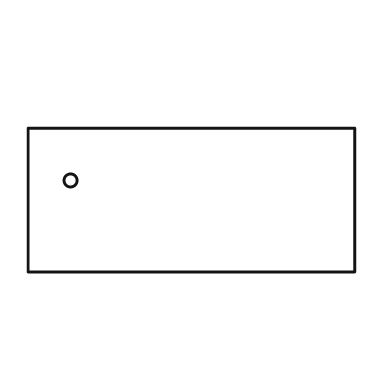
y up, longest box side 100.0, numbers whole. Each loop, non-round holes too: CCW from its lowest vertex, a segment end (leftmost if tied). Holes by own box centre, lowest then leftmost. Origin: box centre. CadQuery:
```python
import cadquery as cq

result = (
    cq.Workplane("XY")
    .moveTo(-50.0, -22.0)
    .lineTo(50.0, -22.0)
    .lineTo(50.0, 22.0)
    .lineTo(-50.0, 22.0)
    .close()
    .moveTo(-37.0, 6.0)
    .circle(2.0)
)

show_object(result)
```